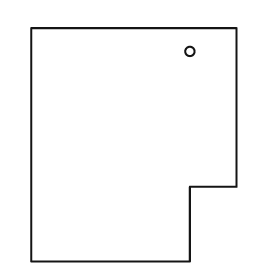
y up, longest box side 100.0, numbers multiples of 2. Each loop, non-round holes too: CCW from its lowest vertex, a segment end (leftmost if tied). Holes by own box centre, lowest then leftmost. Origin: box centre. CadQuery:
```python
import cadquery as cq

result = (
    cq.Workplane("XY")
    .moveTo(-44.0, -50.0)
    .lineTo(24.0, -50.0)
    .lineTo(24.0, -18.0)
    .lineTo(44.0, -18.0)
    .lineTo(44.0, 50.0)
    .lineTo(-44.0, 50.0)
    .close()
    .moveTo(24.0, 40.0)
    .circle(2.0)
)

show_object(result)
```